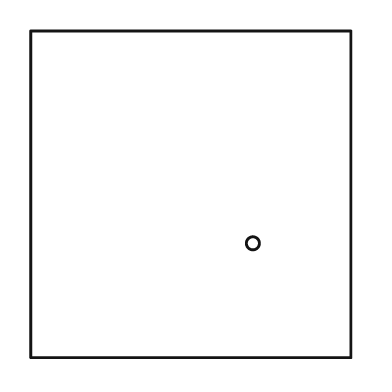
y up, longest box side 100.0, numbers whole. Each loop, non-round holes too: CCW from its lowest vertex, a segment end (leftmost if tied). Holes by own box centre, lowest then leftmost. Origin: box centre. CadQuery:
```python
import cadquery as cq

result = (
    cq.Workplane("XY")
    .moveTo(-49.0, -50.0)
    .lineTo(49.0, -50.0)
    .lineTo(49.0, 50.0)
    .lineTo(-49.0, 50.0)
    .close()
    .moveTo(19.0, -15.0)
    .circle(2.0)
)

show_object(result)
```